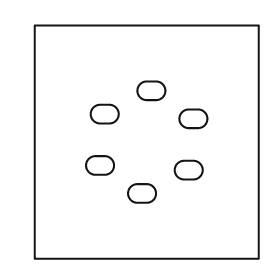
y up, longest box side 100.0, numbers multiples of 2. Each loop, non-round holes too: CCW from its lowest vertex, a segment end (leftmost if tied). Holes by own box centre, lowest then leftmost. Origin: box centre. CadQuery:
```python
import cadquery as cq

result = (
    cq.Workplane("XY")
    .moveTo(-48.0, -50.0)
    .lineTo(48.0, -50.0)
    .lineTo(48.0, 50.0)
    .lineTo(-48.0, 50.0)
    .close()
    .moveTo(-4.0, -26.0)
    .lineTo(0.0, -26.0)
    .threePointArc((4.0, -22.0), (0.0, -18.0))
    .lineTo(-4.0, -18.0)
    .threePointArc((-8.0, -22.0), (-4.0, -26.0))
    .close()
    .moveTo(16.0, -16.0)
    .lineTo(20.0, -16.0)
    .threePointArc((24.0, -12.0), (20.0, -8.0))
    .lineTo(16.0, -8.0)
    .threePointArc((12.0, -12.0), (16.0, -16.0))
    .close()
    .moveTo(-22.0, -14.0)
    .lineTo(-18.0, -14.0)
    .threePointArc((-14.0, -10.0), (-18.0, -6.0))
    .lineTo(-22.0, -6.0)
    .threePointArc((-26.0, -10.0), (-22.0, -14.0))
    .close()
    .moveTo(18.0, 6.0)
    .lineTo(22.0, 6.0)
    .threePointArc((26.0, 10.0), (22.0, 14.0))
    .lineTo(18.0, 14.0)
    .threePointArc((14.0, 10.0), (18.0, 6.0))
    .close()
    .moveTo(-20.0, 8.0)
    .lineTo(-16.0, 8.0)
    .threePointArc((-12.0, 12.0), (-16.0, 16.0))
    .lineTo(-20.0, 16.0)
    .threePointArc((-24.0, 12.0), (-20.0, 8.0))
    .close()
    .moveTo(0.0, 18.0)
    .lineTo(4.0, 18.0)
    .threePointArc((8.0, 22.0), (4.0, 26.0))
    .lineTo(0.0, 26.0)
    .threePointArc((-4.0, 22.0), (0.0, 18.0))
    .close()
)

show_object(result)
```